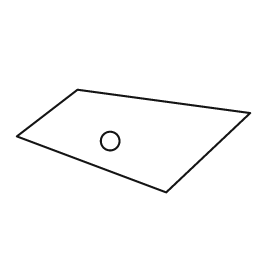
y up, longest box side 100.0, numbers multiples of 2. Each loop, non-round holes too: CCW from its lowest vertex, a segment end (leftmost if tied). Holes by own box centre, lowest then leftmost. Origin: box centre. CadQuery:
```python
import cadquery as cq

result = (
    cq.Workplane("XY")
    .moveTo(14.0, -22.0)
    .lineTo(50.0, 12.0)
    .lineTo(-24.0, 22.0)
    .lineTo(-50.0, 2.0)
    .close()
    .moveTo(-10.0, 0.0)
    .circle(4.0)
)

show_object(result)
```